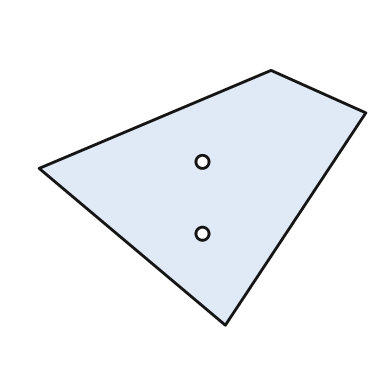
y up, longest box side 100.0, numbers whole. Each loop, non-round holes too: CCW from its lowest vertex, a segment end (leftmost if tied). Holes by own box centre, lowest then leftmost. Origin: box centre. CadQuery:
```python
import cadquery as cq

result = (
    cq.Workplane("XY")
    .moveTo(7.0, -39.0)
    .lineTo(50.0, 26.0)
    .lineTo(21.0, 39.0)
    .lineTo(-50.0, 9.0)
    .close()
    .moveTo(0.0, -11.0)
    .circle(2.0)
    .moveTo(0.0, 11.0)
    .circle(2.0)
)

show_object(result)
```